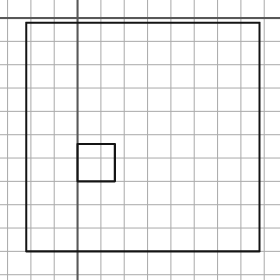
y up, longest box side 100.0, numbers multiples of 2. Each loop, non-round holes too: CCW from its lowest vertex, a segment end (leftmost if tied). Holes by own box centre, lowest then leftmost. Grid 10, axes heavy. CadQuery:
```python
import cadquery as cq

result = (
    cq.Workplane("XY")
    .moveTo(-22.0, -100.0)
    .lineTo(78.0, -100.0)
    .lineTo(78.0, -2.0)
    .lineTo(-22.0, -2.0)
    .close()
    .moveTo(0.0, -70.0)
    .lineTo(16.0, -70.0)
    .lineTo(16.0, -54.0)
    .lineTo(0.0, -54.0)
    .close()
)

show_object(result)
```